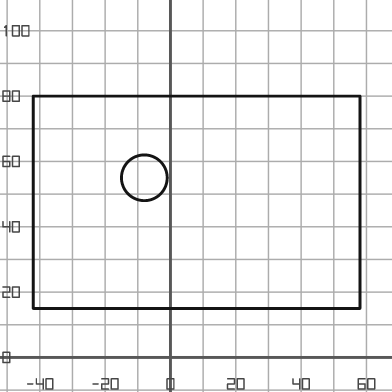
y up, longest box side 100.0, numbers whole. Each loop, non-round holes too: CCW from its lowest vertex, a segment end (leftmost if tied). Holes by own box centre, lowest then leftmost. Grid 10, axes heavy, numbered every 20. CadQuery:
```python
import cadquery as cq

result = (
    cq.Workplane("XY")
    .moveTo(-42.0, 15.0)
    .lineTo(58.0, 15.0)
    .lineTo(58.0, 80.0)
    .lineTo(-42.0, 80.0)
    .close()
    .moveTo(-8.0, 55.0)
    .circle(7.0)
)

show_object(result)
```